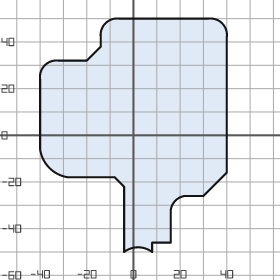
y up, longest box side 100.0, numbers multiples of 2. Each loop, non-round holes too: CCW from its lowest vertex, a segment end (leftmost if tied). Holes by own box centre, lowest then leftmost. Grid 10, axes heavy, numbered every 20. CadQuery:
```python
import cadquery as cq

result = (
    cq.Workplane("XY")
    .moveTo(-4.0, -50.0)
    .threePointArc((2.0, -48.0), (8.0, -50.0))
    .lineTo(8.0, -46.0)
    .lineTo(16.0, -46.0)
    .lineTo(16.0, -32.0)
    .threePointArc((18.0, -28.0), (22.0, -26.0))
    .lineTo(30.0, -26.0)
    .lineTo(40.0, -16.0)
    .lineTo(40.0, 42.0)
    .threePointArc((38.0, 48.0), (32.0, 50.0))
    .lineTo(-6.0, 50.0)
    .threePointArc((-12.0, 48.0), (-14.0, 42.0))
    .lineTo(-14.0, 38.0)
    .lineTo(-20.0, 32.0)
    .lineTo(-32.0, 32.0)
    .threePointArc((-38.0, 30.0), (-40.0, 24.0))
    .lineTo(-40.0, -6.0)
    .threePointArc((-36.0, -14.0), (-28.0, -18.0))
    .lineTo(-8.0, -18.0)
    .lineTo(-4.0, -22.0)
    .close()
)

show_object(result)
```